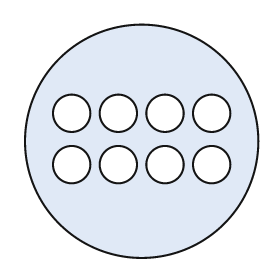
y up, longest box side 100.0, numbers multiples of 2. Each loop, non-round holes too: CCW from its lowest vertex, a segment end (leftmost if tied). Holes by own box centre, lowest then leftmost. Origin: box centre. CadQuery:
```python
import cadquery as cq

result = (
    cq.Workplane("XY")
    .moveTo(0.0, 0.0)
    .circle(50.0)
    .moveTo(-30.0, -10.0)
    .circle(8.0)
    .moveTo(-10.0, -10.0)
    .circle(8.0)
    .moveTo(10.0, -10.0)
    .circle(8.0)
    .moveTo(30.0, -10.0)
    .circle(8.0)
    .moveTo(-30.0, 12.0)
    .circle(8.0)
    .moveTo(-10.0, 12.0)
    .circle(8.0)
    .moveTo(10.0, 12.0)
    .circle(8.0)
    .moveTo(30.0, 12.0)
    .circle(8.0)
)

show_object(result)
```